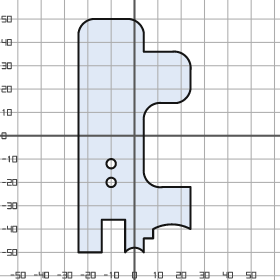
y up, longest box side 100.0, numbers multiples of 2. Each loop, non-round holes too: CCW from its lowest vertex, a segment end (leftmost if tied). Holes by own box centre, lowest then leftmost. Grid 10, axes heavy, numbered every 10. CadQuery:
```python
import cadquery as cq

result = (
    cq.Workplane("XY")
    .moveTo(-24.0, -50.0)
    .lineTo(-14.0, -50.0)
    .lineTo(-14.0, -36.0)
    .lineTo(-4.0, -36.0)
    .lineTo(-4.0, -50.0)
    .threePointArc((0.0, -48.0), (4.0, -50.0))
    .lineTo(4.0, -44.0)
    .lineTo(8.0, -44.0)
    .lineTo(8.0, -40.0)
    .threePointArc((16.0, -38.0), (24.0, -40.0))
    .lineTo(24.0, -22.0)
    .lineTo(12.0, -22.0)
    .threePointArc((6.0, -20.0), (4.0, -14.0))
    .lineTo(4.0, 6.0)
    .threePointArc((6.0, 12.0), (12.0, 14.0))
    .lineTo(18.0, 14.0)
    .threePointArc((22.0, 16.0), (24.0, 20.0))
    .lineTo(24.0, 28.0)
    .threePointArc((22.0, 34.0), (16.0, 36.0))
    .lineTo(4.0, 36.0)
    .lineTo(4.0, 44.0)
    .threePointArc((2.0, 48.0), (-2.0, 50.0))
    .lineTo(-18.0, 50.0)
    .threePointArc((-22.0, 48.0), (-24.0, 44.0))
    .close()
    .moveTo(-10.0, -20.0)
    .circle(2.0)
    .moveTo(-10.0, -12.0)
    .circle(2.0)
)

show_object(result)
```